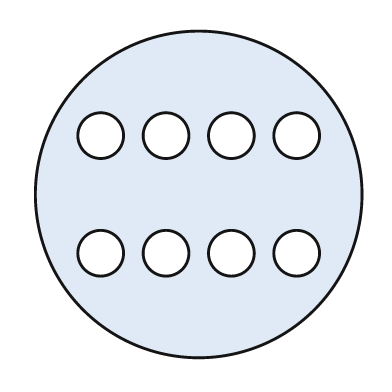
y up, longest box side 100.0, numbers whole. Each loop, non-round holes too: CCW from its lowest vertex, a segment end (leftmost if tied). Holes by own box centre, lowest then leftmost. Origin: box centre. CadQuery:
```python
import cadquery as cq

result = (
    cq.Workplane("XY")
    .moveTo(0.0, 0.0)
    .circle(50.0)
    .moveTo(-30.0, -18.0)
    .circle(7.0)
    .moveTo(-10.0, -18.0)
    .circle(7.0)
    .moveTo(10.0, -18.0)
    .circle(7.0)
    .moveTo(30.0, -18.0)
    .circle(7.0)
    .moveTo(-30.0, 18.0)
    .circle(7.0)
    .moveTo(-10.0, 18.0)
    .circle(7.0)
    .moveTo(10.0, 18.0)
    .circle(7.0)
    .moveTo(30.0, 18.0)
    .circle(7.0)
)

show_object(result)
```